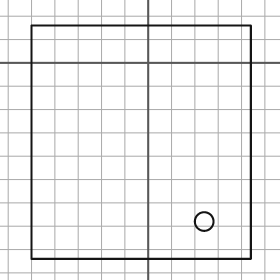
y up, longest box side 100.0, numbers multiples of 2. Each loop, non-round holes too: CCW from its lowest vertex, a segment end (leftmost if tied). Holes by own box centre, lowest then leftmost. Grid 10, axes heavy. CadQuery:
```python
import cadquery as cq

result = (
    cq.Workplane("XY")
    .moveTo(-50.0, -84.0)
    .lineTo(44.0, -84.0)
    .lineTo(44.0, 16.0)
    .lineTo(-50.0, 16.0)
    .close()
    .moveTo(24.0, -68.0)
    .circle(4.0)
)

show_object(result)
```